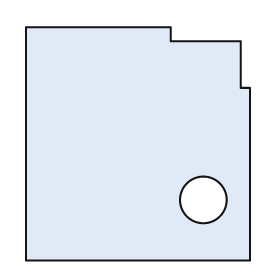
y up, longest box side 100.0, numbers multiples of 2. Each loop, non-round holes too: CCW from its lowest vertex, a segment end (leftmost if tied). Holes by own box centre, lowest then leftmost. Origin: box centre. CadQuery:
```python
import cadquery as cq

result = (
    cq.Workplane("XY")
    .moveTo(-48.0, -50.0)
    .lineTo(48.0, -50.0)
    .lineTo(48.0, 24.0)
    .lineTo(44.0, 24.0)
    .lineTo(44.0, 44.0)
    .lineTo(14.0, 44.0)
    .lineTo(14.0, 50.0)
    .lineTo(-48.0, 50.0)
    .close()
    .moveTo(28.0, -24.0)
    .circle(10.0)
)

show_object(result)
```